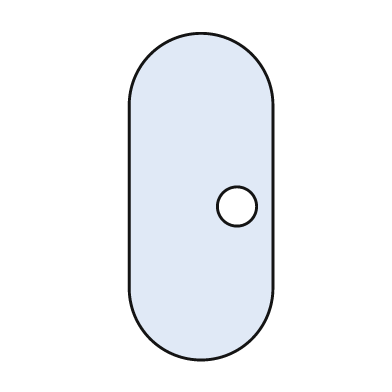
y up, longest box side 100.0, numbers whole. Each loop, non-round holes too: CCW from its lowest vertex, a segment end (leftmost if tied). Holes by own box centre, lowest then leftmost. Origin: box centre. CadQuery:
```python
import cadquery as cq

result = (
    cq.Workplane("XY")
    .moveTo(-22.0, -28.0)
    .threePointArc((0.0, -50.0), (22.0, -28.0))
    .lineTo(22.0, 28.0)
    .threePointArc((0.0, 50.0), (-22.0, 28.0))
    .close()
    .moveTo(11.0, -3.0)
    .circle(6.0)
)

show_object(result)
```